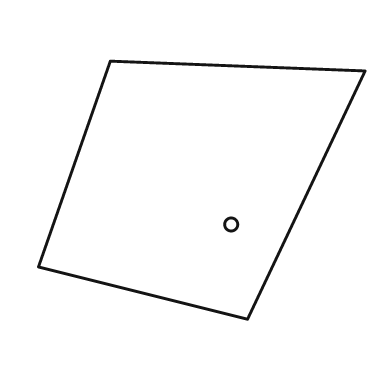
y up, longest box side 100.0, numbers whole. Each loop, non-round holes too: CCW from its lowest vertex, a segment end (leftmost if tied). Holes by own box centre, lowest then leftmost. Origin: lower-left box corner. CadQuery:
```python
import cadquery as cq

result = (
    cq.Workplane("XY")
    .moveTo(64.0, 0.0)
    .lineTo(100.0, 76.0)
    .lineTo(22.0, 79.0)
    .lineTo(0.0, 16.0)
    .close()
    .moveTo(59.0, 29.0)
    .circle(2.0)
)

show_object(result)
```